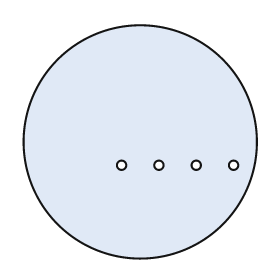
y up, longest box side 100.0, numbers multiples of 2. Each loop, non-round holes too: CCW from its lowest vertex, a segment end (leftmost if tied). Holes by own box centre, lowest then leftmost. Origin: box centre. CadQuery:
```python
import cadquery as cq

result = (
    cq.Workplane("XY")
    .moveTo(0.0, 0.0)
    .circle(50.0)
    .moveTo(-8.0, -10.0)
    .circle(2.0)
    .moveTo(8.0, -10.0)
    .circle(2.0)
    .moveTo(24.0, -10.0)
    .circle(2.0)
    .moveTo(40.0, -10.0)
    .circle(2.0)
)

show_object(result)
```